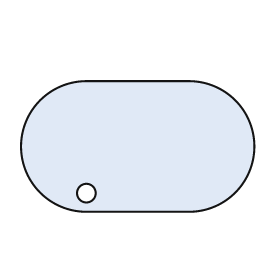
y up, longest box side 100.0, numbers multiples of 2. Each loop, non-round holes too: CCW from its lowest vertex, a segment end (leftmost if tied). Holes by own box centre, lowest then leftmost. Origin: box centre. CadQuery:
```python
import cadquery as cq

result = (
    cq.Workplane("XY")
    .moveTo(-22.0, -28.0)
    .lineTo(22.0, -28.0)
    .threePointArc((50.0, 0.0), (22.0, 28.0))
    .lineTo(-22.0, 28.0)
    .threePointArc((-50.0, 0.0), (-22.0, -28.0))
    .close()
    .moveTo(-22.0, -20.0)
    .circle(4.0)
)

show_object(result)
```